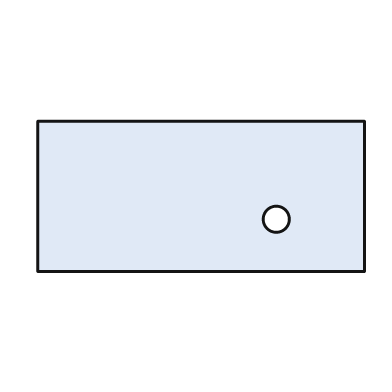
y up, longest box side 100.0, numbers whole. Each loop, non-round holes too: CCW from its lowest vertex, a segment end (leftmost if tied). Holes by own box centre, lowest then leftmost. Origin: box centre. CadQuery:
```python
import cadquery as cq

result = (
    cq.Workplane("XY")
    .moveTo(-50.0, -23.0)
    .lineTo(50.0, -23.0)
    .lineTo(50.0, 23.0)
    .lineTo(-50.0, 23.0)
    .close()
    .moveTo(23.0, -7.0)
    .circle(4.0)
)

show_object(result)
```